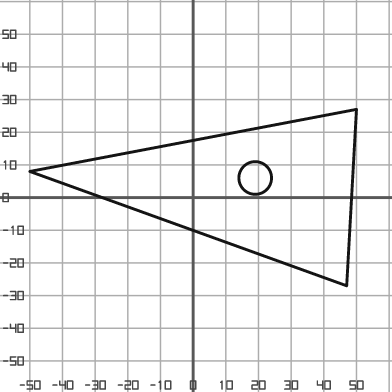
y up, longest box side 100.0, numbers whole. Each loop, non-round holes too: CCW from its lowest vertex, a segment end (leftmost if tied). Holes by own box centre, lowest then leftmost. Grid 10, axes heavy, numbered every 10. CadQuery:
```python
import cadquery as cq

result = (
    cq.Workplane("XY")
    .moveTo(47.0, -27.0)
    .lineTo(50.0, 27.0)
    .lineTo(-50.0, 8.0)
    .close()
    .moveTo(19.0, 6.0)
    .circle(5.0)
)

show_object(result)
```